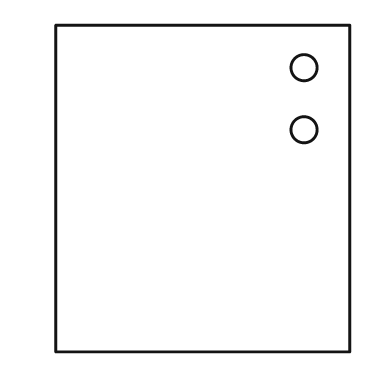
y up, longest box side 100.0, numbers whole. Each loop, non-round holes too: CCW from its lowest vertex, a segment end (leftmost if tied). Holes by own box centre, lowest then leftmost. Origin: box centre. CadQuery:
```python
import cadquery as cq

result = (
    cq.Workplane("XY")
    .moveTo(-45.0, -50.0)
    .lineTo(45.0, -50.0)
    .lineTo(45.0, 50.0)
    .lineTo(-45.0, 50.0)
    .close()
    .moveTo(31.0, 18.0)
    .circle(4.0)
    .moveTo(31.0, 37.0)
    .circle(4.0)
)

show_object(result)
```